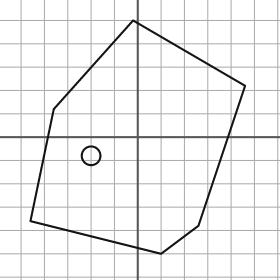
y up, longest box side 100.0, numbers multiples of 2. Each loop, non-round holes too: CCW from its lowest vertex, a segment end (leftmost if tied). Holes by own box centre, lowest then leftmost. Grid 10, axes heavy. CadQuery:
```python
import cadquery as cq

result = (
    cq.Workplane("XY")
    .moveTo(10.0, -50.0)
    .lineTo(26.0, -38.0)
    .lineTo(46.0, 22.0)
    .lineTo(-2.0, 50.0)
    .lineTo(-36.0, 12.0)
    .lineTo(-46.0, -36.0)
    .close()
    .moveTo(-20.0, -8.0)
    .circle(4.0)
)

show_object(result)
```